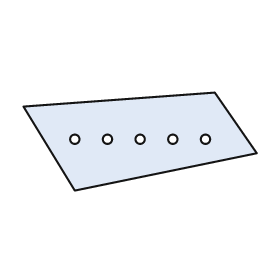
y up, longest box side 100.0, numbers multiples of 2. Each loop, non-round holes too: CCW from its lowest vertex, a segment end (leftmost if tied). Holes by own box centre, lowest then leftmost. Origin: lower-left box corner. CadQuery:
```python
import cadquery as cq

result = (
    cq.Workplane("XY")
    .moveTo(22.0, 0.0)
    .lineTo(100.0, 16.0)
    .lineTo(82.0, 42.0)
    .lineTo(0.0, 36.0)
    .close()
    .moveTo(22.0, 22.0)
    .circle(2.0)
    .moveTo(36.0, 22.0)
    .circle(2.0)
    .moveTo(50.0, 22.0)
    .circle(2.0)
    .moveTo(64.0, 22.0)
    .circle(2.0)
    .moveTo(78.0, 22.0)
    .circle(2.0)
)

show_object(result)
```